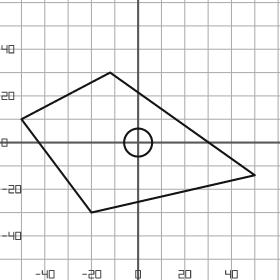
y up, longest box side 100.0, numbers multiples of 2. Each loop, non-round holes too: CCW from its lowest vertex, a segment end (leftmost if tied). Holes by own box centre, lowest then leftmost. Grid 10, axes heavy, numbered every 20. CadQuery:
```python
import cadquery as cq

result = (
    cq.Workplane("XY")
    .moveTo(-20.0, -30.0)
    .lineTo(50.0, -14.0)
    .lineTo(-12.0, 30.0)
    .lineTo(-50.0, 10.0)
    .close()
    .moveTo(0.0, 0.0)
    .circle(6.0)
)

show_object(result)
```